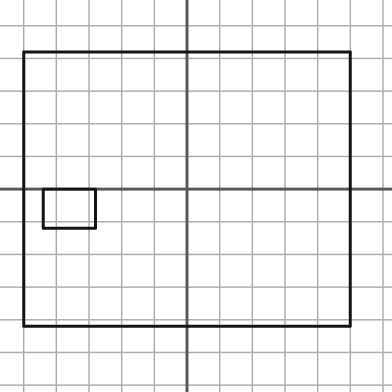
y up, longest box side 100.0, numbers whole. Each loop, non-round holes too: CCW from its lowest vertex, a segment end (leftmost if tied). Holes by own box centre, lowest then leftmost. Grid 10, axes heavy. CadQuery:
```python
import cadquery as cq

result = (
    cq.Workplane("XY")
    .moveTo(-50.0, -42.0)
    .lineTo(50.0, -42.0)
    .lineTo(50.0, 42.0)
    .lineTo(-50.0, 42.0)
    .close()
    .moveTo(-44.0, -12.0)
    .lineTo(-28.0, -12.0)
    .lineTo(-28.0, 0.0)
    .lineTo(-44.0, 0.0)
    .close()
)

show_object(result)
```